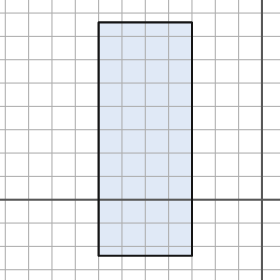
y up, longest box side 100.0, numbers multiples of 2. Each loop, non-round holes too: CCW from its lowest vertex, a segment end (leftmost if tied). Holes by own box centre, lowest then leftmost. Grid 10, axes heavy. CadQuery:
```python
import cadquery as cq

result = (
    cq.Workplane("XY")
    .moveTo(-70.0, -24.0)
    .lineTo(-30.0, -24.0)
    .lineTo(-30.0, 76.0)
    .lineTo(-70.0, 76.0)
    .close()
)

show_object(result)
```